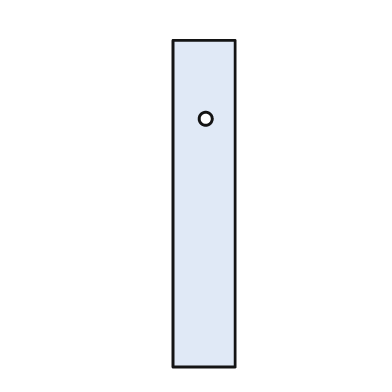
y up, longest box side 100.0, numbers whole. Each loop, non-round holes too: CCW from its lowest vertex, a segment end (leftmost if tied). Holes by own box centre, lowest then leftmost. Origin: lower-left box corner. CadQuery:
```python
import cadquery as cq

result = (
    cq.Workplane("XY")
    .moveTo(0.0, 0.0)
    .lineTo(19.0, 0.0)
    .lineTo(19.0, 100.0)
    .lineTo(0.0, 100.0)
    .close()
    .moveTo(10.0, 76.0)
    .circle(2.0)
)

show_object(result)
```